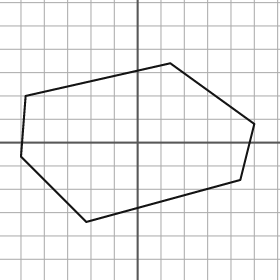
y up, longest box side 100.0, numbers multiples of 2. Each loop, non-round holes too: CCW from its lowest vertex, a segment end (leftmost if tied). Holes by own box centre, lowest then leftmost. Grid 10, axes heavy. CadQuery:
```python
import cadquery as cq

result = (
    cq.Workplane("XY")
    .moveTo(-22.0, -34.0)
    .lineTo(44.0, -16.0)
    .lineTo(50.0, 8.0)
    .lineTo(14.0, 34.0)
    .lineTo(-48.0, 20.0)
    .lineTo(-50.0, -6.0)
    .close()
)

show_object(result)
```